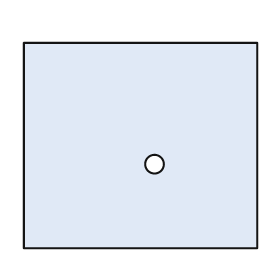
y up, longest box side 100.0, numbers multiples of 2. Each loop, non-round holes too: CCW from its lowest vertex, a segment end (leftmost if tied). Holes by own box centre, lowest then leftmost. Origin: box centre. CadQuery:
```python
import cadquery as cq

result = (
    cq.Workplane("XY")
    .moveTo(-50.0, -44.0)
    .lineTo(50.0, -44.0)
    .lineTo(50.0, 44.0)
    .lineTo(-50.0, 44.0)
    .close()
    .moveTo(6.0, -8.0)
    .circle(4.0)
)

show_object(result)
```